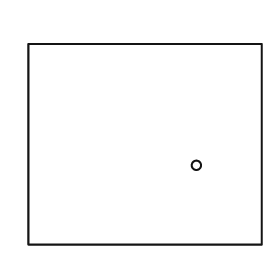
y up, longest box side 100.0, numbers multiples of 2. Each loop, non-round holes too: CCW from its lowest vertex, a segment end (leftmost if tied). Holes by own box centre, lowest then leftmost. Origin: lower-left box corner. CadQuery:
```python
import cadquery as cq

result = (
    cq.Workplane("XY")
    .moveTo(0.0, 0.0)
    .lineTo(100.0, 0.0)
    .lineTo(100.0, 86.0)
    .lineTo(0.0, 86.0)
    .close()
    .moveTo(72.0, 34.0)
    .circle(2.0)
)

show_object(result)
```